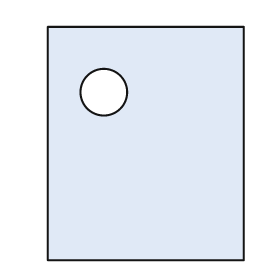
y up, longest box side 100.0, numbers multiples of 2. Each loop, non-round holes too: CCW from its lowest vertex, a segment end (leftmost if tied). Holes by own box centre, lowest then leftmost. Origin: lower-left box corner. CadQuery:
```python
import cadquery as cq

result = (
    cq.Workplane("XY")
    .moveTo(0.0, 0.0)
    .lineTo(84.0, 0.0)
    .lineTo(84.0, 100.0)
    .lineTo(0.0, 100.0)
    .close()
    .moveTo(24.0, 72.0)
    .circle(10.0)
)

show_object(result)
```